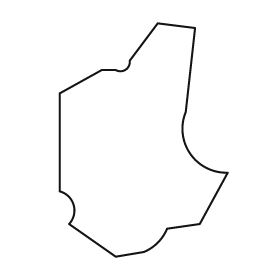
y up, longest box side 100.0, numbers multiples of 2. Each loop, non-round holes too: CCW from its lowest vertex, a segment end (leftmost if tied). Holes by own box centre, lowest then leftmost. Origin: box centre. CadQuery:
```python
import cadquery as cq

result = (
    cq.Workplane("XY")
    .moveTo(-12.0, -50.0)
    .lineTo(0.0, -48.0)
    .threePointArc((6.0, -44.0), (10.0, -38.0))
    .lineTo(24.0, -36.0)
    .lineTo(36.0, -14.0)
    .threePointArc((20.0, -6.0), (18.0, 12.0))
    .lineTo(22.0, 48.0)
    .lineTo(6.0, 50.0)
    .lineTo(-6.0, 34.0)
    .threePointArc((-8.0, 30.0), (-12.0, 30.0))
    .lineTo(-18.0, 30.0)
    .lineTo(-36.0, 20.0)
    .lineTo(-36.0, -22.0)
    .threePointArc((-30.0, -28.0), (-32.0, -36.0))
    .close()
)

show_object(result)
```